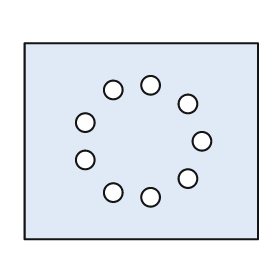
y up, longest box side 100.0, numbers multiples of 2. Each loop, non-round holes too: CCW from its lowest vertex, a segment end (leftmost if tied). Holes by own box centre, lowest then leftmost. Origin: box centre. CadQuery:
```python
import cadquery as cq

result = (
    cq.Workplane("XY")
    .moveTo(-50.0, -42.0)
    .lineTo(50.0, -42.0)
    .lineTo(50.0, 42.0)
    .lineTo(-50.0, 42.0)
    .close()
    .moveTo(4.0, -24.0)
    .circle(4.0)
    .moveTo(-12.0, -22.0)
    .circle(4.0)
    .moveTo(20.0, -16.0)
    .circle(4.0)
    .moveTo(-24.0, -8.0)
    .circle(4.0)
    .moveTo(26.0, 0.0)
    .circle(4.0)
    .moveTo(-24.0, 8.0)
    .circle(4.0)
    .moveTo(20.0, 16.0)
    .circle(4.0)
    .moveTo(-12.0, 22.0)
    .circle(4.0)
    .moveTo(4.0, 24.0)
    .circle(4.0)
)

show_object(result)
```